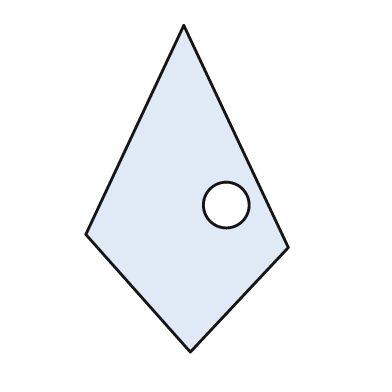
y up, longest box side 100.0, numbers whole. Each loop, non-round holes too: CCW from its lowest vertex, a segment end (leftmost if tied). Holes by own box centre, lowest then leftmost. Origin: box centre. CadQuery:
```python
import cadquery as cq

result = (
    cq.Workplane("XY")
    .moveTo(1.0, -50.0)
    .lineTo(31.0, -18.0)
    .lineTo(-1.0, 50.0)
    .lineTo(-31.0, -14.0)
    .close()
    .moveTo(12.0, -5.0)
    .circle(7.0)
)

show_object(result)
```